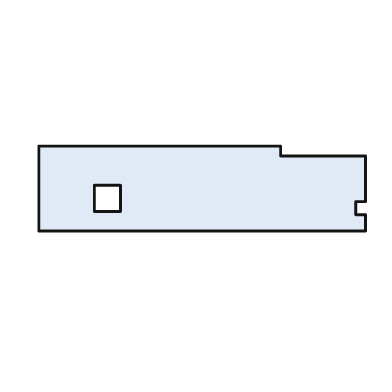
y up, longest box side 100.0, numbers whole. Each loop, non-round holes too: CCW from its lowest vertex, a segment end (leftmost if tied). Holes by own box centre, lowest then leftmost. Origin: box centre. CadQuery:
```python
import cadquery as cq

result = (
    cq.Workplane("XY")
    .moveTo(-50.0, -13.0)
    .lineTo(50.0, -13.0)
    .lineTo(50.0, -8.0)
    .lineTo(47.0, -8.0)
    .lineTo(47.0, -4.0)
    .lineTo(50.0, -4.0)
    .lineTo(50.0, 10.0)
    .lineTo(24.0, 10.0)
    .lineTo(24.0, 13.0)
    .lineTo(-50.0, 13.0)
    .close()
    .moveTo(-33.0, -7.0)
    .lineTo(-25.0, -7.0)
    .lineTo(-25.0, 1.0)
    .lineTo(-33.0, 1.0)
    .close()
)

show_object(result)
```